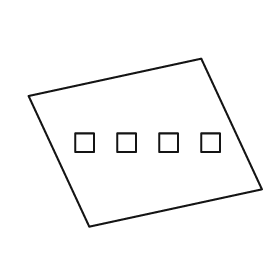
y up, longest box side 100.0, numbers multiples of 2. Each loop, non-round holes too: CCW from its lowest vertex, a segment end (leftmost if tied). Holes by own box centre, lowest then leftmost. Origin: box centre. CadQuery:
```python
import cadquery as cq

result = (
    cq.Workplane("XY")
    .moveTo(-24.0, -36.0)
    .lineTo(50.0, -20.0)
    .lineTo(24.0, 36.0)
    .lineTo(-50.0, 20.0)
    .close()
    .moveTo(-30.0, -4.0)
    .lineTo(-22.0, -4.0)
    .lineTo(-22.0, 4.0)
    .lineTo(-30.0, 4.0)
    .close()
    .moveTo(-12.0, -4.0)
    .lineTo(-4.0, -4.0)
    .lineTo(-4.0, 4.0)
    .lineTo(-12.0, 4.0)
    .close()
    .moveTo(6.0, -4.0)
    .lineTo(14.0, -4.0)
    .lineTo(14.0, 4.0)
    .lineTo(6.0, 4.0)
    .close()
    .moveTo(24.0, -4.0)
    .lineTo(32.0, -4.0)
    .lineTo(32.0, 4.0)
    .lineTo(24.0, 4.0)
    .close()
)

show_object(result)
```